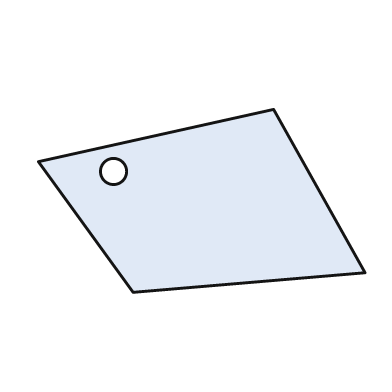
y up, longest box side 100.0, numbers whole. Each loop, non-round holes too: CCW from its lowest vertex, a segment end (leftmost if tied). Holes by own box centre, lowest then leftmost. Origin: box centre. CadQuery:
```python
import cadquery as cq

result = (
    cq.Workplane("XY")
    .moveTo(-21.0, -28.0)
    .lineTo(50.0, -22.0)
    .lineTo(22.0, 28.0)
    .lineTo(-50.0, 12.0)
    .close()
    .moveTo(-27.0, 9.0)
    .circle(4.0)
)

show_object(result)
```